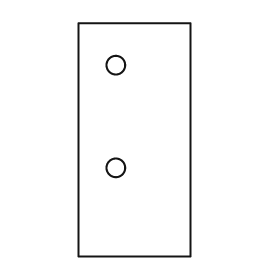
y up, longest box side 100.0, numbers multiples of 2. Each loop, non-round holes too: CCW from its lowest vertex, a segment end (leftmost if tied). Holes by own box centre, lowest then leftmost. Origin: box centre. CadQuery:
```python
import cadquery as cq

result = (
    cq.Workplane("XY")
    .moveTo(-24.0, -50.0)
    .lineTo(24.0, -50.0)
    .lineTo(24.0, 50.0)
    .lineTo(-24.0, 50.0)
    .close()
    .moveTo(-8.0, -12.0)
    .circle(4.0)
    .moveTo(-8.0, 32.0)
    .circle(4.0)
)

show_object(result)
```